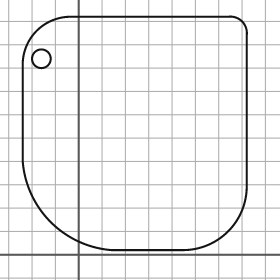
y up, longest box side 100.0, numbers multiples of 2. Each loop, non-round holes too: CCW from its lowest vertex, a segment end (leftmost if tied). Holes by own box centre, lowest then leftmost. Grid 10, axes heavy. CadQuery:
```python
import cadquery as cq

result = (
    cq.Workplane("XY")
    .moveTo(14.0, 2.0)
    .lineTo(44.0, 2.0)
    .threePointArc((64.0, 10.0), (72.0, 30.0))
    .lineTo(72.0, 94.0)
    .threePointArc((70.0, 100.0), (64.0, 102.0))
    .lineTo(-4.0, 102.0)
    .threePointArc((-18.0, 96.0), (-24.0, 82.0))
    .lineTo(-24.0, 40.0)
    .threePointArc((-12.0, 14.0), (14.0, 2.0))
    .close()
    .moveTo(-16.0, 84.0)
    .circle(4.0)
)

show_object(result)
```